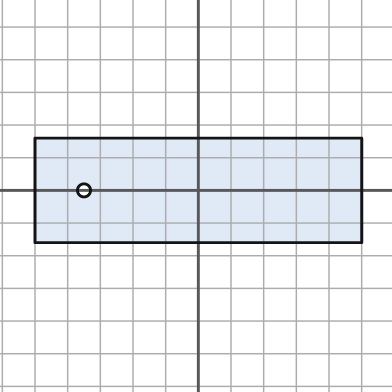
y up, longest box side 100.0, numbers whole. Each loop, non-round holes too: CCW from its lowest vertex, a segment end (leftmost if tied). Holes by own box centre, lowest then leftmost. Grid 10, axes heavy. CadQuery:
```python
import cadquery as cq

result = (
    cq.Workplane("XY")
    .moveTo(-50.0, -16.0)
    .lineTo(50.0, -16.0)
    .lineTo(50.0, 16.0)
    .lineTo(-50.0, 16.0)
    .close()
    .moveTo(-35.0, 0.0)
    .circle(2.0)
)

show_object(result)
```